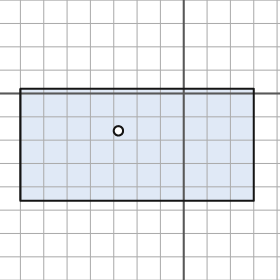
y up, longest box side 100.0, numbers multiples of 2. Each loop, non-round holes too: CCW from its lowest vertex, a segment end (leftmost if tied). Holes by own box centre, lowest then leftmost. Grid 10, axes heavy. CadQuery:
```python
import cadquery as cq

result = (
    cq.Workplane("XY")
    .moveTo(-70.0, -46.0)
    .lineTo(30.0, -46.0)
    .lineTo(30.0, 2.0)
    .lineTo(-70.0, 2.0)
    .close()
    .moveTo(-28.0, -16.0)
    .circle(2.0)
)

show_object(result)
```